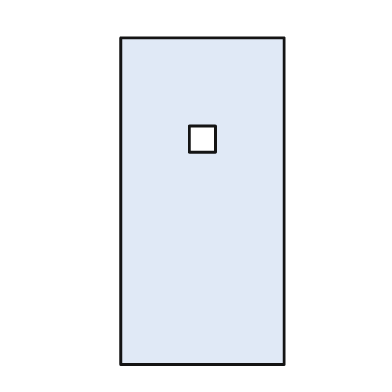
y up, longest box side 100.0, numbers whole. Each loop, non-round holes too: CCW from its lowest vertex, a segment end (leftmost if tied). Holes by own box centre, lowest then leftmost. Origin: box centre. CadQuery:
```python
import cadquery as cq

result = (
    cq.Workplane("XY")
    .moveTo(-25.0, -50.0)
    .lineTo(25.0, -50.0)
    .lineTo(25.0, 50.0)
    .lineTo(-25.0, 50.0)
    .close()
    .moveTo(-4.0, 15.0)
    .lineTo(4.0, 15.0)
    .lineTo(4.0, 23.0)
    .lineTo(-4.0, 23.0)
    .close()
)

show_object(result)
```